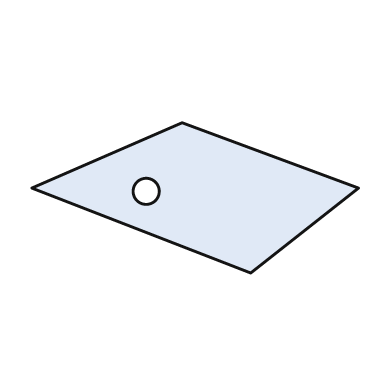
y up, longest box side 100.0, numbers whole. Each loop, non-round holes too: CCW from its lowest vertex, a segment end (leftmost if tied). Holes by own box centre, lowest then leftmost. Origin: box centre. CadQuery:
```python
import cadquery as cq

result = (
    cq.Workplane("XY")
    .moveTo(17.0, -23.0)
    .lineTo(50.0, 3.0)
    .lineTo(-4.0, 23.0)
    .lineTo(-50.0, 3.0)
    .close()
    .moveTo(-15.0, 2.0)
    .circle(4.0)
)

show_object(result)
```